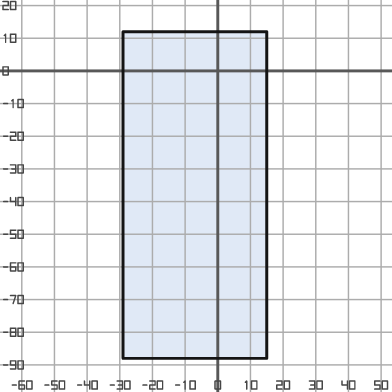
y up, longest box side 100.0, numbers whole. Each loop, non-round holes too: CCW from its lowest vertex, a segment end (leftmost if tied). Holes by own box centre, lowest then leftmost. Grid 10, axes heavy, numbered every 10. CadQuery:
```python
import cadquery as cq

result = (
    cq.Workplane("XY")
    .moveTo(-29.0, -88.0)
    .lineTo(15.0, -88.0)
    .lineTo(15.0, 12.0)
    .lineTo(-29.0, 12.0)
    .close()
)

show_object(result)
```